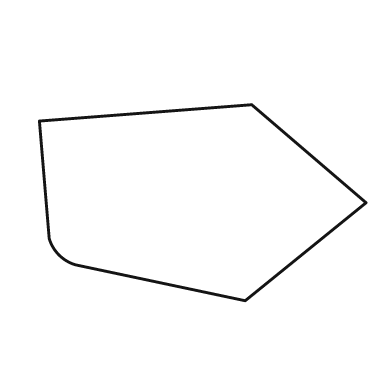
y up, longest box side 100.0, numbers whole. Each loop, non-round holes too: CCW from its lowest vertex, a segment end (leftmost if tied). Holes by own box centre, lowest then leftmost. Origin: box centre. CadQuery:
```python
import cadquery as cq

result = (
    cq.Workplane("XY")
    .moveTo(13.0, -30.0)
    .lineTo(50.0, 0.0)
    .lineTo(15.0, 30.0)
    .lineTo(-50.0, 25.0)
    .lineTo(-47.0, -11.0)
    .threePointArc((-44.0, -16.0), (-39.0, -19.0))
    .close()
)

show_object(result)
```